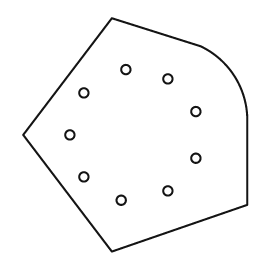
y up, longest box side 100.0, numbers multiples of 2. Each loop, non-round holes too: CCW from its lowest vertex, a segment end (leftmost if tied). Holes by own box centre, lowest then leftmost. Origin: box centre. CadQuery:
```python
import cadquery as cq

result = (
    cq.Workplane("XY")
    .moveTo(-10.0, -50.0)
    .lineTo(48.0, -30.0)
    .lineTo(48.0, 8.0)
    .threePointArc((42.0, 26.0), (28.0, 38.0))
    .lineTo(-10.0, 50.0)
    .lineTo(-48.0, 0.0)
    .close()
    .moveTo(-6.0, -28.0)
    .circle(2.0)
    .moveTo(14.0, -24.0)
    .circle(2.0)
    .moveTo(-22.0, -18.0)
    .circle(2.0)
    .moveTo(26.0, -10.0)
    .circle(2.0)
    .moveTo(-28.0, 0.0)
    .circle(2.0)
    .moveTo(26.0, 10.0)
    .circle(2.0)
    .moveTo(-22.0, 18.0)
    .circle(2.0)
    .moveTo(14.0, 24.0)
    .circle(2.0)
    .moveTo(-4.0, 28.0)
    .circle(2.0)
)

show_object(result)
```